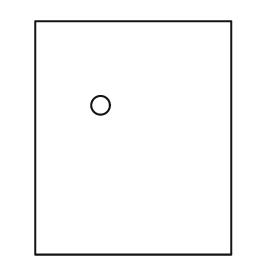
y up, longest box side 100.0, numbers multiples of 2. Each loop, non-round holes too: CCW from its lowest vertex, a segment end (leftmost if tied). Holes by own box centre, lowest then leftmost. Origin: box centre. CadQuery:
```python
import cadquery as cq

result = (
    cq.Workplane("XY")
    .moveTo(-42.0, -50.0)
    .lineTo(42.0, -50.0)
    .lineTo(42.0, 50.0)
    .lineTo(-42.0, 50.0)
    .close()
    .moveTo(-14.0, 14.0)
    .circle(4.0)
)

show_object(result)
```